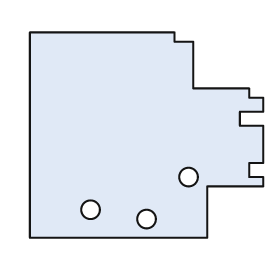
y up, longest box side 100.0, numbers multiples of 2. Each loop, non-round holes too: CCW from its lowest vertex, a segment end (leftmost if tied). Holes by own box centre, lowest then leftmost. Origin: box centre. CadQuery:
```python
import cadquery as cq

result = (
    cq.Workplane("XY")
    .moveTo(-50.0, -44.0)
    .lineTo(26.0, -44.0)
    .lineTo(26.0, -22.0)
    .lineTo(50.0, -22.0)
    .lineTo(50.0, -18.0)
    .lineTo(44.0, -18.0)
    .lineTo(44.0, -12.0)
    .lineTo(50.0, -12.0)
    .lineTo(50.0, 4.0)
    .lineTo(40.0, 4.0)
    .lineTo(40.0, 10.0)
    .lineTo(50.0, 10.0)
    .lineTo(50.0, 16.0)
    .lineTo(44.0, 16.0)
    .lineTo(44.0, 20.0)
    .lineTo(20.0, 20.0)
    .lineTo(20.0, 40.0)
    .lineTo(12.0, 40.0)
    .lineTo(12.0, 44.0)
    .lineTo(-50.0, 44.0)
    .close()
    .moveTo(0.0, -36.0)
    .circle(4.0)
    .moveTo(-24.0, -32.0)
    .circle(4.0)
    .moveTo(18.0, -18.0)
    .circle(4.0)
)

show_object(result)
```